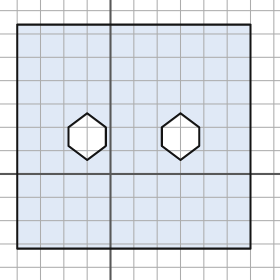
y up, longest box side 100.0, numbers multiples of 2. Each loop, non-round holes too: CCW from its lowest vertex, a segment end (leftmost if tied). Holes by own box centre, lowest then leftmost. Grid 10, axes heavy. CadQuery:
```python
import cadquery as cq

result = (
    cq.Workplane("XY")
    .moveTo(-40.0, -32.0)
    .lineTo(60.0, -32.0)
    .lineTo(60.0, 64.0)
    .lineTo(-40.0, 64.0)
    .close()
    .moveTo(-10.0, 6.0)
    .lineTo(-2.0, 12.0)
    .lineTo(-2.0, 20.0)
    .lineTo(-10.0, 26.0)
    .lineTo(-18.0, 20.0)
    .lineTo(-18.0, 12.0)
    .close()
    .moveTo(30.0, 6.0)
    .lineTo(38.0, 12.0)
    .lineTo(38.0, 20.0)
    .lineTo(30.0, 26.0)
    .lineTo(22.0, 20.0)
    .lineTo(22.0, 12.0)
    .close()
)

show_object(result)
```